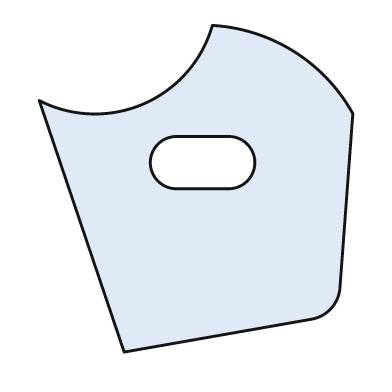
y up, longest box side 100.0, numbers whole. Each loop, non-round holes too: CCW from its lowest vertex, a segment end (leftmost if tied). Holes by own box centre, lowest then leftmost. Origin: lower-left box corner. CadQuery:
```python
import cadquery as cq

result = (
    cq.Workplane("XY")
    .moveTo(26.0, 0.0)
    .lineTo(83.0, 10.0)
    .threePointArc((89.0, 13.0), (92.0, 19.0))
    .lineTo(96.0, 73.0)
    .threePointArc((78.0, 92.0), (53.0, 100.0))
    .threePointArc((32.0, 76.0), (0.0, 77.0))
    .close()
    .moveTo(42.0, 50.0)
    .lineTo(58.0, 50.0)
    .threePointArc((66.0, 58.0), (58.0, 66.0))
    .lineTo(42.0, 66.0)
    .threePointArc((34.0, 58.0), (42.0, 50.0))
    .close()
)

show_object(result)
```